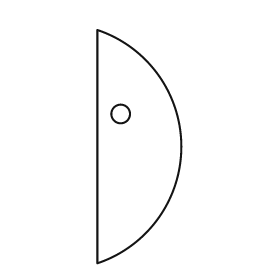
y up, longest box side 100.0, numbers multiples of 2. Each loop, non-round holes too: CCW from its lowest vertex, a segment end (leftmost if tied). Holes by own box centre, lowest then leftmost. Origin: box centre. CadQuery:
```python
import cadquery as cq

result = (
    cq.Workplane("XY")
    .moveTo(-18.0, -50.0)
    .threePointArc((18.0, 0.0), (-18.0, 50.0))
    .close()
    .moveTo(-8.0, 14.0)
    .circle(4.0)
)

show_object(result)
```